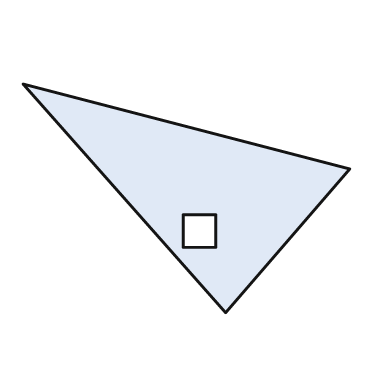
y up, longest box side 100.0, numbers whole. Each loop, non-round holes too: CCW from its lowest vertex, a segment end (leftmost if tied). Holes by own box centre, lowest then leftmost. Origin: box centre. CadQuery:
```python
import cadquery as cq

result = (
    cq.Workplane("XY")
    .moveTo(12.0, -35.0)
    .lineTo(50.0, 9.0)
    .lineTo(-50.0, 35.0)
    .close()
    .moveTo(-1.0, -15.0)
    .lineTo(9.0, -15.0)
    .lineTo(9.0, -5.0)
    .lineTo(-1.0, -5.0)
    .close()
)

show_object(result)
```